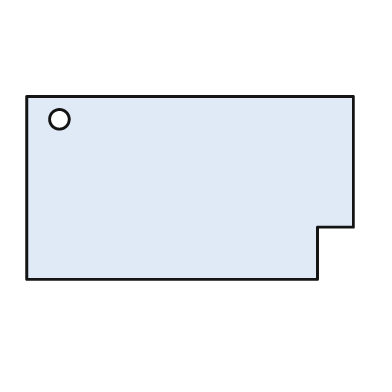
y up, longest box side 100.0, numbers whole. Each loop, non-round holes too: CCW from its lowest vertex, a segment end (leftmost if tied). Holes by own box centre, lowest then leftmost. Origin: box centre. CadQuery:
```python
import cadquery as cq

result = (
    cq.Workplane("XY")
    .moveTo(-50.0, -28.0)
    .lineTo(39.0, -28.0)
    .lineTo(39.0, -12.0)
    .lineTo(50.0, -12.0)
    .lineTo(50.0, 28.0)
    .lineTo(-50.0, 28.0)
    .close()
    .moveTo(-40.0, 21.0)
    .circle(3.0)
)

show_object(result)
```